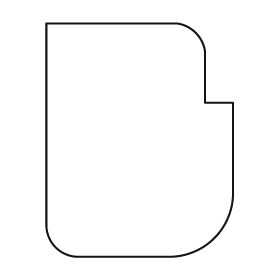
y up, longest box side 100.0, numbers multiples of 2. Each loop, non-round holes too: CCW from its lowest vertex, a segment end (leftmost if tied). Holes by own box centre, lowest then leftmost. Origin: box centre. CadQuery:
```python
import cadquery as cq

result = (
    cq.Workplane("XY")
    .moveTo(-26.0, -50.0)
    .lineTo(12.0, -50.0)
    .threePointArc((32.0, -42.0), (40.0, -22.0))
    .lineTo(40.0, 16.0)
    .lineTo(28.0, 16.0)
    .lineTo(28.0, 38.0)
    .threePointArc((24.0, 46.0), (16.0, 50.0))
    .lineTo(-40.0, 50.0)
    .lineTo(-40.0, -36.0)
    .threePointArc((-36.0, -46.0), (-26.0, -50.0))
    .close()
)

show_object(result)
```